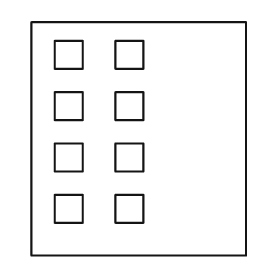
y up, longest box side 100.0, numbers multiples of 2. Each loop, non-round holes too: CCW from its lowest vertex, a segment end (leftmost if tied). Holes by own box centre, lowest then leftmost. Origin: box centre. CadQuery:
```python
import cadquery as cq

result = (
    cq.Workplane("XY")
    .moveTo(-46.0, -50.0)
    .lineTo(46.0, -50.0)
    .lineTo(46.0, 50.0)
    .lineTo(-46.0, 50.0)
    .close()
    .moveTo(-36.0, -36.0)
    .lineTo(-24.0, -36.0)
    .lineTo(-24.0, -24.0)
    .lineTo(-36.0, -24.0)
    .close()
    .moveTo(-10.0, -36.0)
    .lineTo(2.0, -36.0)
    .lineTo(2.0, -24.0)
    .lineTo(-10.0, -24.0)
    .close()
    .moveTo(-36.0, -14.0)
    .lineTo(-24.0, -14.0)
    .lineTo(-24.0, -2.0)
    .lineTo(-36.0, -2.0)
    .close()
    .moveTo(-10.0, -14.0)
    .lineTo(2.0, -14.0)
    .lineTo(2.0, -2.0)
    .lineTo(-10.0, -2.0)
    .close()
    .moveTo(-36.0, 8.0)
    .lineTo(-24.0, 8.0)
    .lineTo(-24.0, 20.0)
    .lineTo(-36.0, 20.0)
    .close()
    .moveTo(-10.0, 8.0)
    .lineTo(2.0, 8.0)
    .lineTo(2.0, 20.0)
    .lineTo(-10.0, 20.0)
    .close()
    .moveTo(-36.0, 30.0)
    .lineTo(-24.0, 30.0)
    .lineTo(-24.0, 42.0)
    .lineTo(-36.0, 42.0)
    .close()
    .moveTo(-10.0, 30.0)
    .lineTo(2.0, 30.0)
    .lineTo(2.0, 42.0)
    .lineTo(-10.0, 42.0)
    .close()
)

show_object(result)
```